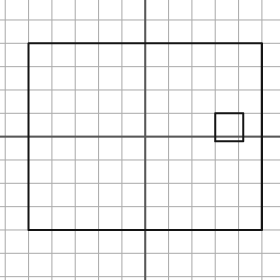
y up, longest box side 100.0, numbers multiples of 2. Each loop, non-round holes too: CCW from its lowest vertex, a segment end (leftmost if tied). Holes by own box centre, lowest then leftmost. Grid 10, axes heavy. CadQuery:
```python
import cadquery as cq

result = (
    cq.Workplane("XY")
    .moveTo(-50.0, -40.0)
    .lineTo(50.0, -40.0)
    .lineTo(50.0, 40.0)
    .lineTo(-50.0, 40.0)
    .close()
    .moveTo(30.0, -2.0)
    .lineTo(42.0, -2.0)
    .lineTo(42.0, 10.0)
    .lineTo(30.0, 10.0)
    .close()
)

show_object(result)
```